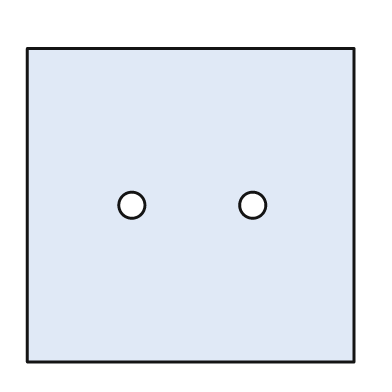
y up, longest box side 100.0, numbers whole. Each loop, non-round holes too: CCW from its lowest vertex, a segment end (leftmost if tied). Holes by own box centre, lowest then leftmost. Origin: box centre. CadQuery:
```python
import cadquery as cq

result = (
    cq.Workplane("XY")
    .moveTo(-50.0, -48.0)
    .lineTo(50.0, -48.0)
    .lineTo(50.0, 48.0)
    .lineTo(-50.0, 48.0)
    .close()
    .moveTo(-18.0, 0.0)
    .circle(4.0)
    .moveTo(19.0, 0.0)
    .circle(4.0)
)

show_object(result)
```